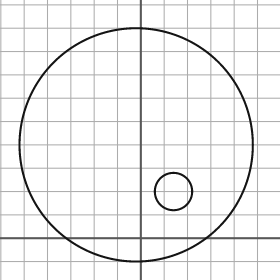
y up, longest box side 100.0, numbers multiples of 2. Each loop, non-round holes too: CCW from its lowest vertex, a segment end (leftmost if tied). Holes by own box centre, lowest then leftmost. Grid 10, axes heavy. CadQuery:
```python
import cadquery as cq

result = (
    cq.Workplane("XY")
    .moveTo(-2.0, 40.0)
    .circle(50.0)
    .moveTo(14.0, 20.0)
    .circle(8.0)
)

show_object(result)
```